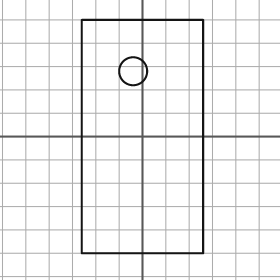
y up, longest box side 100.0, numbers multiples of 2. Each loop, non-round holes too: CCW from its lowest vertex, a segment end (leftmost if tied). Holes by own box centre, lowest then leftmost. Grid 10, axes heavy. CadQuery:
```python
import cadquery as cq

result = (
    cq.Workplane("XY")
    .moveTo(-26.0, -50.0)
    .lineTo(26.0, -50.0)
    .lineTo(26.0, 50.0)
    .lineTo(-26.0, 50.0)
    .close()
    .moveTo(-4.0, 28.0)
    .circle(6.0)
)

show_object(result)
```